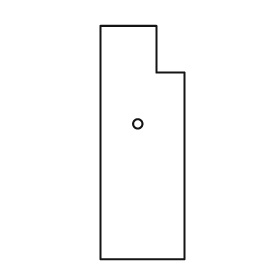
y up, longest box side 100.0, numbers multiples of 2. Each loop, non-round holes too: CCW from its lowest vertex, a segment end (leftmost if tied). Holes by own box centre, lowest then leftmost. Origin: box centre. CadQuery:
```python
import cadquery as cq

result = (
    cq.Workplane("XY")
    .moveTo(-18.0, -50.0)
    .lineTo(18.0, -50.0)
    .lineTo(18.0, 30.0)
    .lineTo(6.0, 30.0)
    .lineTo(6.0, 50.0)
    .lineTo(-18.0, 50.0)
    .close()
    .moveTo(-2.0, 8.0)
    .circle(2.0)
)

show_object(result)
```